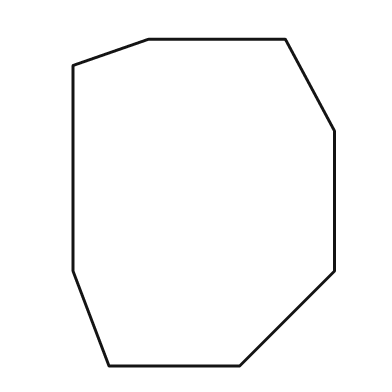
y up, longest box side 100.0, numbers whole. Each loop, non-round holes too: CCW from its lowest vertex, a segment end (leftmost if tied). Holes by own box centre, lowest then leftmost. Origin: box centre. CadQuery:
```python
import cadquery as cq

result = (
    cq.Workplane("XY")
    .moveTo(-29.0, -50.0)
    .lineTo(11.0, -50.0)
    .lineTo(40.0, -21.0)
    .lineTo(40.0, 22.0)
    .lineTo(25.0, 50.0)
    .lineTo(-17.0, 50.0)
    .lineTo(-40.0, 42.0)
    .lineTo(-40.0, -21.0)
    .close()
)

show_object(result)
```